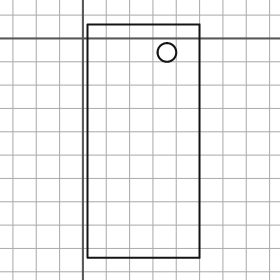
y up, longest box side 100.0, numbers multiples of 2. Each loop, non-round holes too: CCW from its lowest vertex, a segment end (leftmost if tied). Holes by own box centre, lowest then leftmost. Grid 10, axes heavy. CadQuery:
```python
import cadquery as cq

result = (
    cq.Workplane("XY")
    .moveTo(2.0, -94.0)
    .lineTo(50.0, -94.0)
    .lineTo(50.0, 6.0)
    .lineTo(2.0, 6.0)
    .close()
    .moveTo(36.0, -6.0)
    .circle(4.0)
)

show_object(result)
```